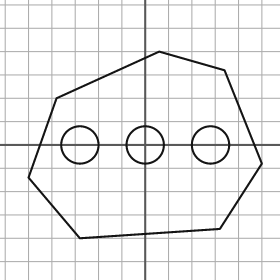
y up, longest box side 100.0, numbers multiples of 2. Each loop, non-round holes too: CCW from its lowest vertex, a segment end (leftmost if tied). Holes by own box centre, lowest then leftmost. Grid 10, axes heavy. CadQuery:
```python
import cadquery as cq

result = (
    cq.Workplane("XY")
    .moveTo(-28.0, -40.0)
    .lineTo(32.0, -36.0)
    .lineTo(50.0, -8.0)
    .lineTo(34.0, 32.0)
    .lineTo(6.0, 40.0)
    .lineTo(-38.0, 20.0)
    .lineTo(-50.0, -14.0)
    .close()
    .moveTo(-28.0, 0.0)
    .circle(8.0)
    .moveTo(0.0, 0.0)
    .circle(8.0)
    .moveTo(28.0, 0.0)
    .circle(8.0)
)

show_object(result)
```